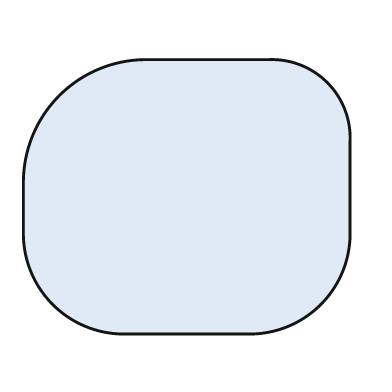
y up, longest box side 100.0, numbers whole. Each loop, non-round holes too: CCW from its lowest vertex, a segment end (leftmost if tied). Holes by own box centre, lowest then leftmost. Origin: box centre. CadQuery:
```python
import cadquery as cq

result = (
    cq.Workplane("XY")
    .moveTo(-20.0, -42.0)
    .lineTo(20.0, -42.0)
    .threePointArc((41.0, -33.0), (50.0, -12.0))
    .lineTo(50.0, 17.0)
    .threePointArc((43.0, 35.0), (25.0, 42.0))
    .lineTo(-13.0, 42.0)
    .threePointArc((-39.0, 31.0), (-50.0, 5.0))
    .lineTo(-50.0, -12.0)
    .threePointArc((-41.0, -33.0), (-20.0, -42.0))
    .close()
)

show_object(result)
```